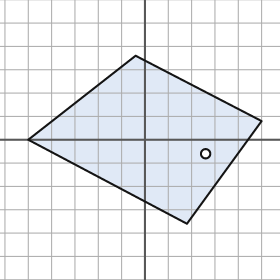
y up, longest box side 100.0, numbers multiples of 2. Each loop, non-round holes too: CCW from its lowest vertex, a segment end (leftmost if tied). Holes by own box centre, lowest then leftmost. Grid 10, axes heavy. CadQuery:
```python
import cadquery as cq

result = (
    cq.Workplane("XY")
    .moveTo(18.0, -36.0)
    .lineTo(50.0, 8.0)
    .lineTo(-4.0, 36.0)
    .lineTo(-50.0, 0.0)
    .close()
    .moveTo(26.0, -6.0)
    .circle(2.0)
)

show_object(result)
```